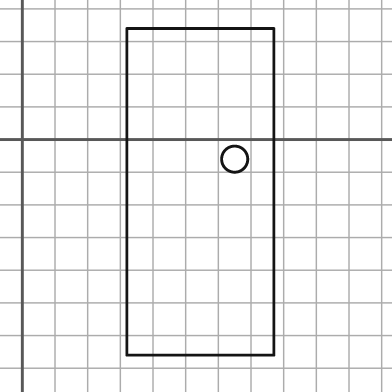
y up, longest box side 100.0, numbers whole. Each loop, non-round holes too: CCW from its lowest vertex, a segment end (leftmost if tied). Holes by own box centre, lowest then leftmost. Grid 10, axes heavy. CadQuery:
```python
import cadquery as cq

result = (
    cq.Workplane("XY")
    .moveTo(32.0, -66.0)
    .lineTo(77.0, -66.0)
    .lineTo(77.0, 34.0)
    .lineTo(32.0, 34.0)
    .close()
    .moveTo(65.0, -6.0)
    .circle(4.0)
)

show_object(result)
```